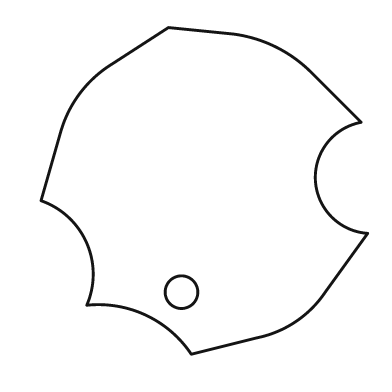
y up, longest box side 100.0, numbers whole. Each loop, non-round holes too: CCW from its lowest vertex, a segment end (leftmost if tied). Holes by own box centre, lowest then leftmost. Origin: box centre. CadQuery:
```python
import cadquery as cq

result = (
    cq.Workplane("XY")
    .moveTo(-4.0, -50.0)
    .lineTo(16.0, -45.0)
    .threePointArc((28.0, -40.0), (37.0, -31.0))
    .lineTo(50.0, -13.0)
    .threePointArc((34.0, 3.0), (48.0, 21.0))
    .lineTo(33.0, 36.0)
    .threePointArc((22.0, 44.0), (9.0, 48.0))
    .lineTo(-11.0, 50.0)
    .lineTo(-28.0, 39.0)
    .threePointArc((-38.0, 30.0), (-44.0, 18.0))
    .lineTo(-50.0, -3.0)
    .threePointArc((-36.0, -16.0), (-36.0, -35.0))
    .threePointArc((-18.0, -38.0), (-4.0, -50.0))
    .close()
    .moveTo(-7.0, -31.0)
    .circle(5.0)
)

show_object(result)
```